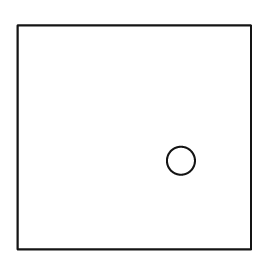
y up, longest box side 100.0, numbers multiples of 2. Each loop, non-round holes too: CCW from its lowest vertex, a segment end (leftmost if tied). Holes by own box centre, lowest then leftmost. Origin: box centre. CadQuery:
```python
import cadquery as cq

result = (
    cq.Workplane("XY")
    .moveTo(-50.0, -48.0)
    .lineTo(50.0, -48.0)
    .lineTo(50.0, 48.0)
    .lineTo(-50.0, 48.0)
    .close()
    .moveTo(20.0, -10.0)
    .circle(6.0)
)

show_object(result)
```